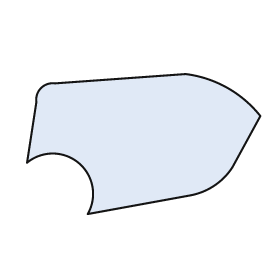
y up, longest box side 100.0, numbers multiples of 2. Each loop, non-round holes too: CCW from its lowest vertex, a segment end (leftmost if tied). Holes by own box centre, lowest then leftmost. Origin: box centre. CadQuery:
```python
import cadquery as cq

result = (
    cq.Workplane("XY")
    .moveTo(-24.0, -30.0)
    .lineTo(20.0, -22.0)
    .threePointArc((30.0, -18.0), (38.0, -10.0))
    .lineTo(50.0, 12.0)
    .threePointArc((36.0, 24.0), (18.0, 30.0))
    .lineTo(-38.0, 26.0)
    .threePointArc((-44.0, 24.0), (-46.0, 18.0))
    .lineTo(-50.0, -8.0)
    .threePointArc((-28.0, -8.0), (-24.0, -30.0))
    .close()
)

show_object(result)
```